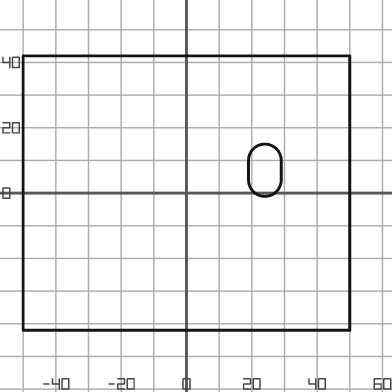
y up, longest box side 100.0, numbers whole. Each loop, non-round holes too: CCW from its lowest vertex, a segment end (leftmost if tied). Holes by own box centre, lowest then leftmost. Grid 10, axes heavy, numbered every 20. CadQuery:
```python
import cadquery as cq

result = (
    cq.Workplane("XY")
    .moveTo(-50.0, -42.0)
    .lineTo(50.0, -42.0)
    .lineTo(50.0, 42.0)
    .lineTo(-50.0, 42.0)
    .close()
    .moveTo(19.0, 4.0)
    .threePointArc((24.0, -1.0), (29.0, 4.0))
    .lineTo(29.0, 10.0)
    .threePointArc((24.0, 15.0), (19.0, 10.0))
    .close()
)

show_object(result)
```